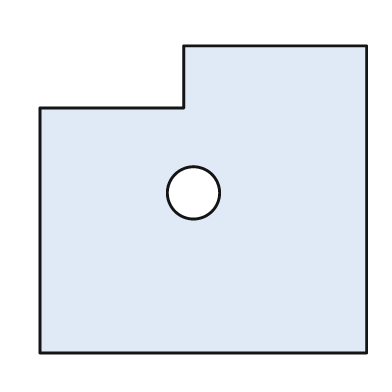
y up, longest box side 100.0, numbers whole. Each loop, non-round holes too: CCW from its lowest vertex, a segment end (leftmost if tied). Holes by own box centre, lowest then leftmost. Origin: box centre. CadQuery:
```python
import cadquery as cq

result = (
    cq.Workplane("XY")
    .moveTo(-50.0, -47.0)
    .lineTo(50.0, -47.0)
    .lineTo(50.0, 47.0)
    .lineTo(-6.0, 47.0)
    .lineTo(-6.0, 28.0)
    .lineTo(-50.0, 28.0)
    .close()
    .moveTo(-3.0, 2.0)
    .circle(8.0)
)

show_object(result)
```